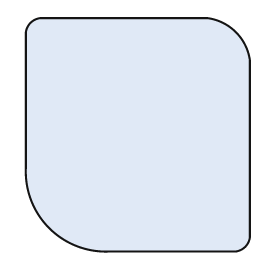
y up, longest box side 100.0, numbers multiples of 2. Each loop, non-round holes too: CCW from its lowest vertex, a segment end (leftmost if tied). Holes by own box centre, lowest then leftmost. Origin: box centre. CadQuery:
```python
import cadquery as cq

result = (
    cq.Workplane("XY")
    .moveTo(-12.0, -50.0)
    .lineTo(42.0, -50.0)
    .threePointArc((46.0, -48.0), (48.0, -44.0))
    .lineTo(48.0, 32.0)
    .threePointArc((42.0, 44.0), (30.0, 50.0))
    .lineTo(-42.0, 50.0)
    .threePointArc((-46.0, 48.0), (-48.0, 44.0))
    .lineTo(-48.0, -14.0)
    .threePointArc((-38.0, -40.0), (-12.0, -50.0))
    .close()
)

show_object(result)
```